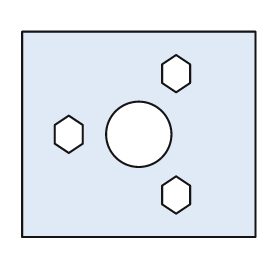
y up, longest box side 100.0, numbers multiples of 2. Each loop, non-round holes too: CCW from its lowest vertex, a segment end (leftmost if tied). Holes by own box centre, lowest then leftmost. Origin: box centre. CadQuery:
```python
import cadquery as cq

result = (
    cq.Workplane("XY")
    .moveTo(-50.0, -44.0)
    .lineTo(50.0, -44.0)
    .lineTo(50.0, 44.0)
    .lineTo(-50.0, 44.0)
    .close()
    .moveTo(16.0, -34.0)
    .lineTo(22.0, -30.0)
    .lineTo(22.0, -22.0)
    .lineTo(16.0, -18.0)
    .lineTo(10.0, -22.0)
    .lineTo(10.0, -30.0)
    .close()
    .moveTo(-30.0, -8.0)
    .lineTo(-24.0, -4.0)
    .lineTo(-24.0, 4.0)
    .lineTo(-30.0, 8.0)
    .lineTo(-36.0, 4.0)
    .lineTo(-36.0, -4.0)
    .close()
    .moveTo(0.0, 0.0)
    .circle(14.0)
    .moveTo(16.0, 18.0)
    .lineTo(22.0, 22.0)
    .lineTo(22.0, 30.0)
    .lineTo(16.0, 34.0)
    .lineTo(10.0, 30.0)
    .lineTo(10.0, 22.0)
    .close()
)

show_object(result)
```